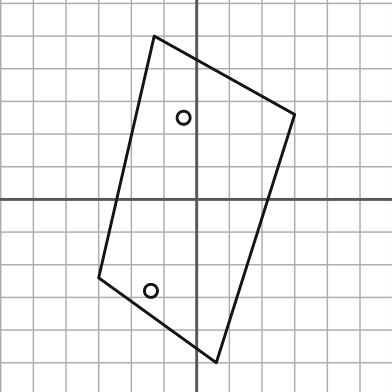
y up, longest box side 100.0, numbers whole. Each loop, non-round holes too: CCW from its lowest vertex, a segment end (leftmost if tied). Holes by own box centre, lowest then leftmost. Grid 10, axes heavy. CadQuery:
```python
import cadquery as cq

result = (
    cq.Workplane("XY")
    .moveTo(6.0, -50.0)
    .lineTo(30.0, 26.0)
    .lineTo(-13.0, 50.0)
    .lineTo(-30.0, -24.0)
    .close()
    .moveTo(-14.0, -28.0)
    .circle(2.0)
    .moveTo(-4.0, 25.0)
    .circle(2.0)
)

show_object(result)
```